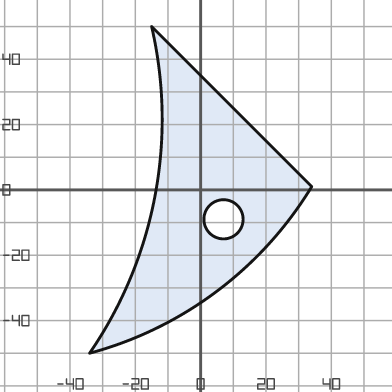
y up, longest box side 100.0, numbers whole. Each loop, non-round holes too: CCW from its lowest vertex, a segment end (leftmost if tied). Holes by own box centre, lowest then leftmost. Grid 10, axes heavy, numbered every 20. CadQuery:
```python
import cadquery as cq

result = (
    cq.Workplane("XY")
    .moveTo(-34.0, -50.0)
    .threePointArc((5.0, -31.0), (34.0, 1.0))
    .lineTo(-15.0, 50.0)
    .threePointArc((-14.0, -2.0), (-34.0, -50.0))
    .close()
    .moveTo(7.0, -9.0)
    .circle(6.0)
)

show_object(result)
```